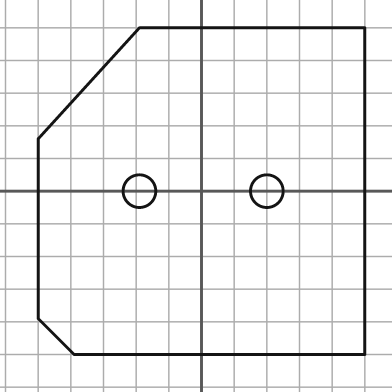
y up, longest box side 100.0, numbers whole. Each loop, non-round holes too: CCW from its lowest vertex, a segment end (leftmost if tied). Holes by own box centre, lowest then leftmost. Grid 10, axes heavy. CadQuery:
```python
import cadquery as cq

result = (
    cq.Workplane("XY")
    .moveTo(-39.0, -50.0)
    .lineTo(50.0, -50.0)
    .lineTo(50.0, 50.0)
    .lineTo(-19.0, 50.0)
    .lineTo(-50.0, 16.0)
    .lineTo(-50.0, -39.0)
    .close()
    .moveTo(-19.0, 0.0)
    .circle(5.0)
    .moveTo(20.0, 0.0)
    .circle(5.0)
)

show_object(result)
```